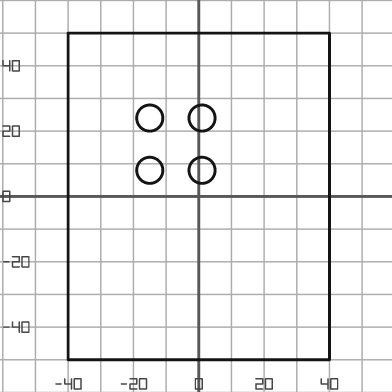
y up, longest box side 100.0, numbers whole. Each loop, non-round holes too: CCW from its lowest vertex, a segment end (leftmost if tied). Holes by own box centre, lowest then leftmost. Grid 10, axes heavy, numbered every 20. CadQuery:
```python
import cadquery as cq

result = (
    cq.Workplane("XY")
    .moveTo(-40.0, -50.0)
    .lineTo(40.0, -50.0)
    .lineTo(40.0, 50.0)
    .lineTo(-40.0, 50.0)
    .close()
    .moveTo(-15.0, 8.0)
    .circle(4.0)
    .moveTo(1.0, 8.0)
    .circle(4.0)
    .moveTo(-15.0, 24.0)
    .circle(4.0)
    .moveTo(1.0, 24.0)
    .circle(4.0)
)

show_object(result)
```